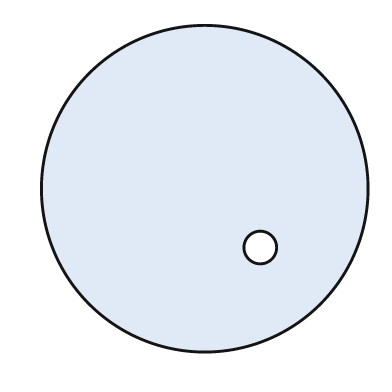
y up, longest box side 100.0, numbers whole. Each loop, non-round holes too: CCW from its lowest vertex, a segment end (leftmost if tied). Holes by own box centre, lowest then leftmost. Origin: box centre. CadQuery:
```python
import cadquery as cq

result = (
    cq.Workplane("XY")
    .moveTo(0.0, 0.0)
    .circle(50.0)
    .moveTo(17.0, -18.0)
    .circle(5.0)
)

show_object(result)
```